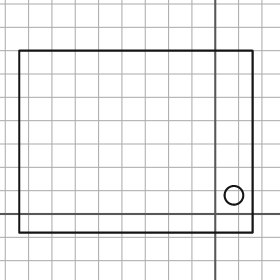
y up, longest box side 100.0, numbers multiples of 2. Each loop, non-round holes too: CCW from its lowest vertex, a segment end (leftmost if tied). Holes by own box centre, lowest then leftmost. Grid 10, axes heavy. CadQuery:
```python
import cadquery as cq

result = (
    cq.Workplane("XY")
    .moveTo(-84.0, -8.0)
    .lineTo(16.0, -8.0)
    .lineTo(16.0, 70.0)
    .lineTo(-84.0, 70.0)
    .close()
    .moveTo(8.0, 8.0)
    .circle(4.0)
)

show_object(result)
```